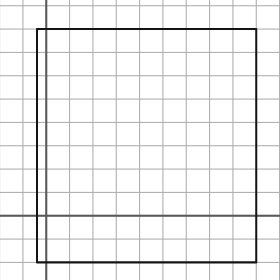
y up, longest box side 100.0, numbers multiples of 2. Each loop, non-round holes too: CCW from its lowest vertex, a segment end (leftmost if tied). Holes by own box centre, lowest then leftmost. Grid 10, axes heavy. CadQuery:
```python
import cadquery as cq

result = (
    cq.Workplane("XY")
    .moveTo(-4.0, -20.0)
    .lineTo(90.0, -20.0)
    .lineTo(90.0, 80.0)
    .lineTo(-4.0, 80.0)
    .close()
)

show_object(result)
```